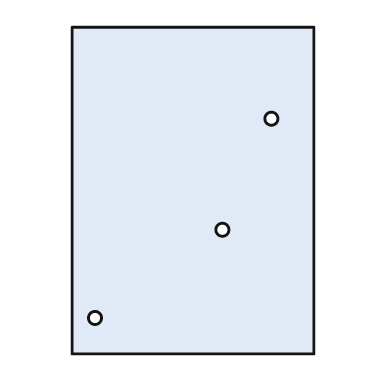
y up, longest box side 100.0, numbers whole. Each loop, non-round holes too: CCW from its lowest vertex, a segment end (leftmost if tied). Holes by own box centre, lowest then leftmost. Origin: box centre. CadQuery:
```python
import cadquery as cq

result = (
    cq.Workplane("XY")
    .moveTo(-37.0, -50.0)
    .lineTo(37.0, -50.0)
    .lineTo(37.0, 50.0)
    .lineTo(-37.0, 50.0)
    .close()
    .moveTo(-30.0, -39.0)
    .circle(2.0)
    .moveTo(9.0, -12.0)
    .circle(2.0)
    .moveTo(24.0, 22.0)
    .circle(2.0)
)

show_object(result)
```